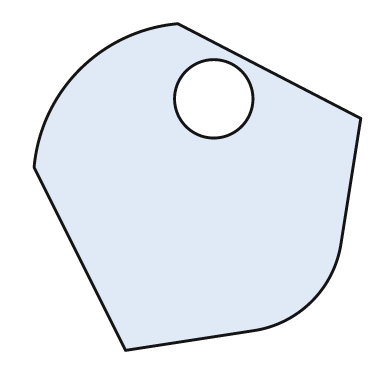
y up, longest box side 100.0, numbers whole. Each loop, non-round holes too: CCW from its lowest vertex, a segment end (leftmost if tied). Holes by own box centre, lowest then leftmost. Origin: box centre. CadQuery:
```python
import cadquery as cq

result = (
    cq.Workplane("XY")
    .moveTo(-22.0, -50.0)
    .lineTo(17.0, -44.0)
    .threePointArc((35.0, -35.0), (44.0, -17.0))
    .lineTo(50.0, 21.0)
    .lineTo(-6.0, 50.0)
    .threePointArc((-36.0, 36.0), (-50.0, 6.0))
    .close()
    .moveTo(5.0, 27.0)
    .circle(12.0)
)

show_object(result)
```